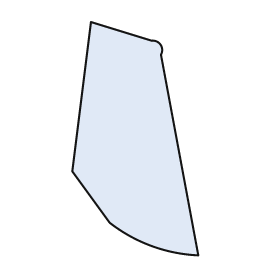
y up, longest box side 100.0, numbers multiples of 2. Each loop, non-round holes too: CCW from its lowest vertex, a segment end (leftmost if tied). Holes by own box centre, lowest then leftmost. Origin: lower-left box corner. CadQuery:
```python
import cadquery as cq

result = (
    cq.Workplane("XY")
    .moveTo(54.0, 0.0)
    .lineTo(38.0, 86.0)
    .threePointArc((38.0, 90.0), (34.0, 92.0))
    .lineTo(8.0, 100.0)
    .lineTo(0.0, 36.0)
    .lineTo(16.0, 14.0)
    .threePointArc((34.0, 4.0), (54.0, 0.0))
    .close()
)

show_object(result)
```